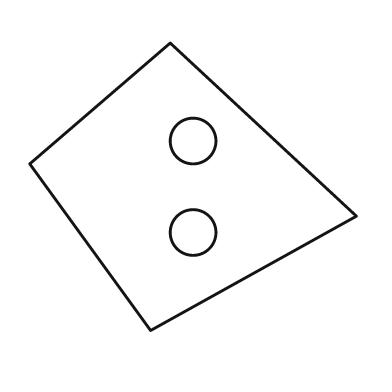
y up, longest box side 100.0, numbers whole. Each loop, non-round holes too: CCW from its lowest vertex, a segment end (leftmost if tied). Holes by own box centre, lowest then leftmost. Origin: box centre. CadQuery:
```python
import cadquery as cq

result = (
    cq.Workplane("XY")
    .moveTo(-13.0, -44.0)
    .lineTo(50.0, -9.0)
    .lineTo(-7.0, 44.0)
    .lineTo(-50.0, 7.0)
    .close()
    .moveTo(0.0, -14.0)
    .circle(7.0)
    .moveTo(0.0, 14.0)
    .circle(7.0)
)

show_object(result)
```